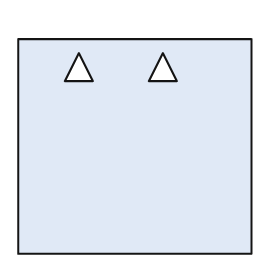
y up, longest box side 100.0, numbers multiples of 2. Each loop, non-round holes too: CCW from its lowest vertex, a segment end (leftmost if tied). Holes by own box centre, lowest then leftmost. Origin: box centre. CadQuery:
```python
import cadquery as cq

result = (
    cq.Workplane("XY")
    .moveTo(-50.0, -46.0)
    .lineTo(50.0, -46.0)
    .lineTo(50.0, 46.0)
    .lineTo(-50.0, 46.0)
    .close()
    .moveTo(-30.0, 28.0)
    .lineTo(-18.0, 28.0)
    .lineTo(-24.0, 40.0)
    .close()
    .moveTo(6.0, 28.0)
    .lineTo(18.0, 28.0)
    .lineTo(12.0, 40.0)
    .close()
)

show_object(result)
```